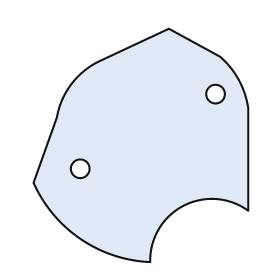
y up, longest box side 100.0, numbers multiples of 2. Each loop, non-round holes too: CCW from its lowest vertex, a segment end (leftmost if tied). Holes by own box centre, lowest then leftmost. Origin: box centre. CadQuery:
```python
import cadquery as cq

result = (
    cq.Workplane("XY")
    .moveTo(4.0, -50.0)
    .threePointArc((18.0, -26.0), (46.0, -28.0))
    .lineTo(46.0, 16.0)
    .threePointArc((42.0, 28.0), (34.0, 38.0))
    .lineTo(12.0, 50.0)
    .lineTo(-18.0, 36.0)
    .threePointArc((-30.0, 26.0), (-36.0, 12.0))
    .lineTo(-46.0, -16.0)
    .threePointArc((-26.0, -40.0), (4.0, -50.0))
    .close()
    .moveTo(-26.0, -10.0)
    .circle(4.0)
    .moveTo(32.0, 22.0)
    .circle(4.0)
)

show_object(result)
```